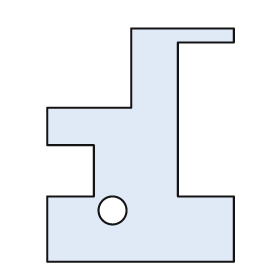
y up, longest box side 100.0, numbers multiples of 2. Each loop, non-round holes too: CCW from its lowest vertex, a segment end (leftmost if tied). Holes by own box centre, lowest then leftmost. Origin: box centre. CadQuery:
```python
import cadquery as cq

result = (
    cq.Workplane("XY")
    .moveTo(-40.0, -50.0)
    .lineTo(40.0, -50.0)
    .lineTo(40.0, -22.0)
    .lineTo(16.0, -22.0)
    .lineTo(16.0, 44.0)
    .lineTo(40.0, 44.0)
    .lineTo(40.0, 50.0)
    .lineTo(-4.0, 50.0)
    .lineTo(-4.0, 16.0)
    .lineTo(-40.0, 16.0)
    .lineTo(-40.0, 0.0)
    .lineTo(-20.0, 0.0)
    .lineTo(-20.0, -22.0)
    .lineTo(-40.0, -22.0)
    .close()
    .moveTo(-12.0, -28.0)
    .circle(6.0)
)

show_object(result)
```